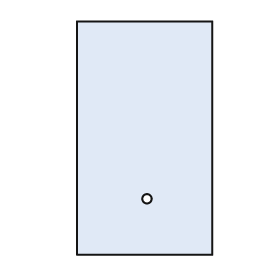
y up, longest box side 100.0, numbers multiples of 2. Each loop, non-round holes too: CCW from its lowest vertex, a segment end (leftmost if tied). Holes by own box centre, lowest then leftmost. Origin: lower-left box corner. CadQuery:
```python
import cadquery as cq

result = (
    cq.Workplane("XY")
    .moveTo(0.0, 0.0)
    .lineTo(58.0, 0.0)
    .lineTo(58.0, 100.0)
    .lineTo(0.0, 100.0)
    .close()
    .moveTo(30.0, 24.0)
    .circle(2.0)
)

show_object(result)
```